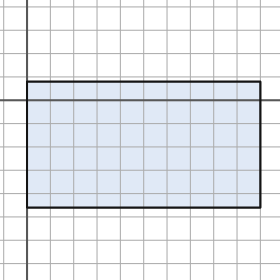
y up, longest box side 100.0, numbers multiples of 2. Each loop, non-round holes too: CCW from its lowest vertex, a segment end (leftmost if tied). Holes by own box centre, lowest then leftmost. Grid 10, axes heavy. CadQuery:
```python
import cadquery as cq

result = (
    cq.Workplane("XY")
    .moveTo(0.0, -46.0)
    .lineTo(100.0, -46.0)
    .lineTo(100.0, 8.0)
    .lineTo(0.0, 8.0)
    .close()
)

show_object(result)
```